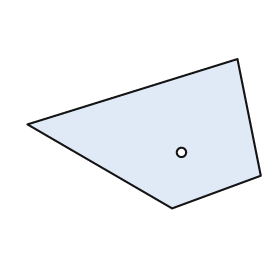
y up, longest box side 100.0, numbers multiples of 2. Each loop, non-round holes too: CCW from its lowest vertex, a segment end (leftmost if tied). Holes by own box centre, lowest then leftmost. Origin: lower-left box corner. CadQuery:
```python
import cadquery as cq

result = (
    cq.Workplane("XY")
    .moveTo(62.0, 0.0)
    .lineTo(100.0, 14.0)
    .lineTo(90.0, 64.0)
    .lineTo(0.0, 36.0)
    .close()
    .moveTo(66.0, 24.0)
    .circle(2.0)
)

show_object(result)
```